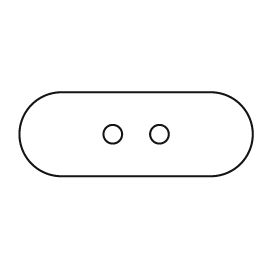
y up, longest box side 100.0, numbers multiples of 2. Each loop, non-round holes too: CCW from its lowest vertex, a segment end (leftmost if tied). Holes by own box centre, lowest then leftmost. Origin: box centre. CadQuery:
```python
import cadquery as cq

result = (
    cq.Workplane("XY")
    .moveTo(-32.0, -18.0)
    .lineTo(32.0, -18.0)
    .threePointArc((50.0, 0.0), (32.0, 18.0))
    .lineTo(-32.0, 18.0)
    .threePointArc((-50.0, 0.0), (-32.0, -18.0))
    .close()
    .moveTo(-10.0, 0.0)
    .circle(4.0)
    .moveTo(10.0, 0.0)
    .circle(4.0)
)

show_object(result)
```